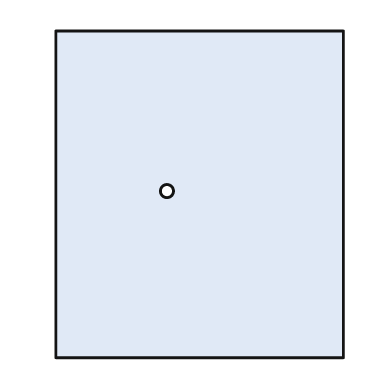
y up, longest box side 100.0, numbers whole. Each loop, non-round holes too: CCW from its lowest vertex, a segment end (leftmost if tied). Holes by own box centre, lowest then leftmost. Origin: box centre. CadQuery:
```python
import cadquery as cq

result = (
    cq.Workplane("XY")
    .moveTo(-44.0, -50.0)
    .lineTo(44.0, -50.0)
    .lineTo(44.0, 50.0)
    .lineTo(-44.0, 50.0)
    .close()
    .moveTo(-10.0, 1.0)
    .circle(2.0)
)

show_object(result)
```